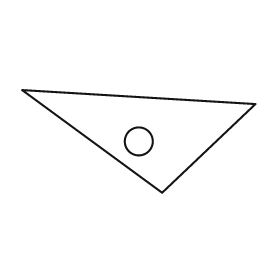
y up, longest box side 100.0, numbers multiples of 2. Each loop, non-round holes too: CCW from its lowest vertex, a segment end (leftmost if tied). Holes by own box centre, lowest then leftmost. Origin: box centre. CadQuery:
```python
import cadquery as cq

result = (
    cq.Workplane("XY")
    .moveTo(10.0, -22.0)
    .lineTo(50.0, 16.0)
    .lineTo(-50.0, 22.0)
    .close()
    .moveTo(0.0, 0.0)
    .circle(6.0)
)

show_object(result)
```